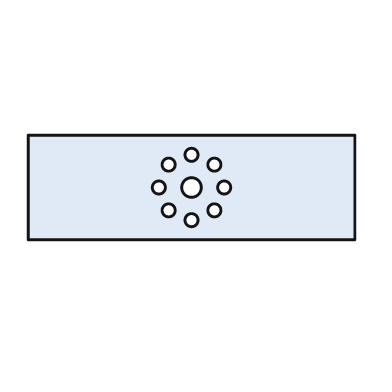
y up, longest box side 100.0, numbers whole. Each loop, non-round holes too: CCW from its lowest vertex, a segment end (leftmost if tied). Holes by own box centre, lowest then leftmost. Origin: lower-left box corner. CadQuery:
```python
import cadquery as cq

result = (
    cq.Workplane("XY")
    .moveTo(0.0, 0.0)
    .lineTo(100.0, 0.0)
    .lineTo(100.0, 32.0)
    .lineTo(0.0, 32.0)
    .close()
    .moveTo(50.0, 6.0)
    .circle(2.0)
    .moveTo(43.0, 9.0)
    .circle(2.0)
    .moveTo(57.0, 9.0)
    .circle(2.0)
    .moveTo(40.0, 16.0)
    .circle(2.0)
    .moveTo(50.0, 16.0)
    .circle(3.0)
    .moveTo(60.0, 16.0)
    .circle(2.0)
    .moveTo(43.0, 23.0)
    .circle(2.0)
    .moveTo(57.0, 23.0)
    .circle(2.0)
    .moveTo(50.0, 26.0)
    .circle(2.0)
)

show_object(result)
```